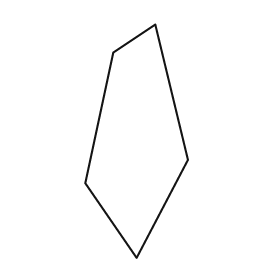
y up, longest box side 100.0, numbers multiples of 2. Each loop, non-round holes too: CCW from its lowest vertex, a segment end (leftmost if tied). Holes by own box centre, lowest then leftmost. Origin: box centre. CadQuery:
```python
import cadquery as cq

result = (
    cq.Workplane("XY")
    .moveTo(0.0, -50.0)
    .lineTo(22.0, -8.0)
    .lineTo(8.0, 50.0)
    .lineTo(-10.0, 38.0)
    .lineTo(-22.0, -18.0)
    .close()
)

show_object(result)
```